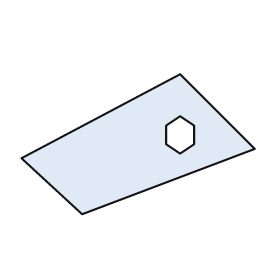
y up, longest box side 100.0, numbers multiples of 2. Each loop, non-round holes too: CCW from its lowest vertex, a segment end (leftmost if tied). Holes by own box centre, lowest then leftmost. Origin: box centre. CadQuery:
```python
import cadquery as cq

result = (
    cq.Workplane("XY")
    .moveTo(-24.0, -30.0)
    .lineTo(50.0, -2.0)
    .lineTo(18.0, 30.0)
    .lineTo(-50.0, -6.0)
    .close()
    .moveTo(18.0, -4.0)
    .lineTo(24.0, 0.0)
    .lineTo(24.0, 8.0)
    .lineTo(18.0, 12.0)
    .lineTo(12.0, 8.0)
    .lineTo(12.0, 0.0)
    .close()
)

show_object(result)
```